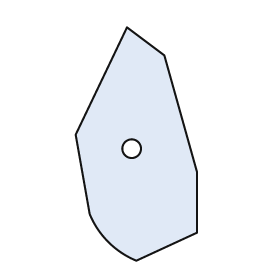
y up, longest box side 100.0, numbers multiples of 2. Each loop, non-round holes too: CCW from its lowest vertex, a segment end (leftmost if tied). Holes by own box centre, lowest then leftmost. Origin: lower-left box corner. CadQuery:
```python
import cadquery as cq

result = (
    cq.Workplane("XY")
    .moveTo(26.0, 0.0)
    .lineTo(52.0, 12.0)
    .lineTo(52.0, 38.0)
    .lineTo(38.0, 88.0)
    .lineTo(22.0, 100.0)
    .lineTo(0.0, 54.0)
    .lineTo(6.0, 20.0)
    .threePointArc((14.0, 8.0), (26.0, 0.0))
    .close()
    .moveTo(24.0, 48.0)
    .circle(4.0)
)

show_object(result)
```